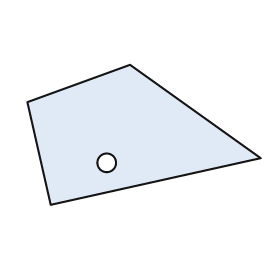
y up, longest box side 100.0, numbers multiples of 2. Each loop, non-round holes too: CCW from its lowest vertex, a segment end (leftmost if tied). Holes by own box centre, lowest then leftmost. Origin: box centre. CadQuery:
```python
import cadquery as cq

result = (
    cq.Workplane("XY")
    .moveTo(-40.0, -30.0)
    .lineTo(50.0, -10.0)
    .lineTo(-6.0, 30.0)
    .lineTo(-50.0, 14.0)
    .close()
    .moveTo(-16.0, -12.0)
    .circle(4.0)
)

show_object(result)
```